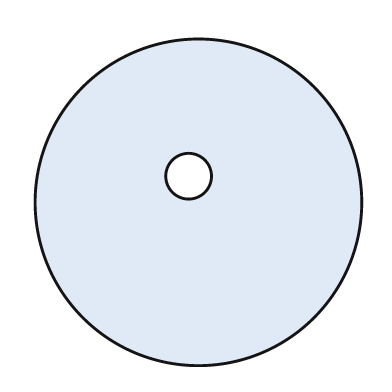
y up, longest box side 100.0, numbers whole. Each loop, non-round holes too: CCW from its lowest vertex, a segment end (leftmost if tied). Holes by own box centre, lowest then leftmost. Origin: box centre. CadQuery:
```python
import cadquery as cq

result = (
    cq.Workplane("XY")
    .moveTo(0.0, 0.0)
    .circle(50.0)
    .moveTo(-3.0, 8.0)
    .circle(7.0)
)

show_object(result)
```